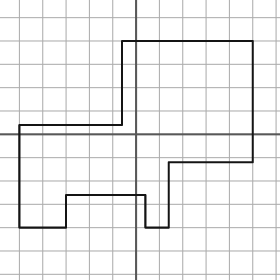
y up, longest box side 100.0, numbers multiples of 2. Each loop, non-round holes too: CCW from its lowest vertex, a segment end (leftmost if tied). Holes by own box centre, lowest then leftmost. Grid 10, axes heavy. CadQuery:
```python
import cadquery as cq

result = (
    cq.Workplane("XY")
    .moveTo(-50.0, -40.0)
    .lineTo(-30.0, -40.0)
    .lineTo(-30.0, -26.0)
    .lineTo(4.0, -26.0)
    .lineTo(4.0, -40.0)
    .lineTo(14.0, -40.0)
    .lineTo(14.0, -12.0)
    .lineTo(50.0, -12.0)
    .lineTo(50.0, 40.0)
    .lineTo(-6.0, 40.0)
    .lineTo(-6.0, 4.0)
    .lineTo(-50.0, 4.0)
    .close()
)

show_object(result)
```